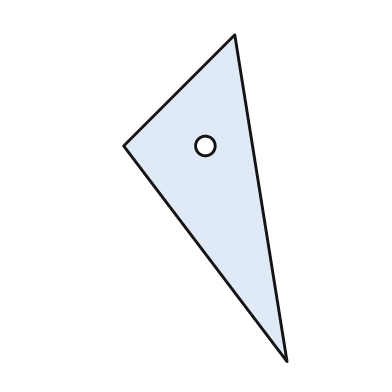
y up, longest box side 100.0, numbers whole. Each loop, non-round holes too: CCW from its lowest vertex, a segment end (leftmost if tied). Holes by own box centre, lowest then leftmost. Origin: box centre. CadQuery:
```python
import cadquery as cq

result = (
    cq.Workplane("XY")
    .moveTo(25.0, -50.0)
    .lineTo(9.0, 50.0)
    .lineTo(-25.0, 16.0)
    .close()
    .moveTo(0.0, 16.0)
    .circle(3.0)
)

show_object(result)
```